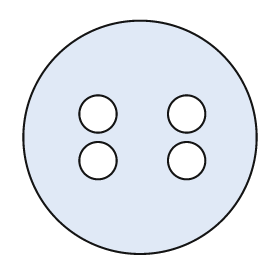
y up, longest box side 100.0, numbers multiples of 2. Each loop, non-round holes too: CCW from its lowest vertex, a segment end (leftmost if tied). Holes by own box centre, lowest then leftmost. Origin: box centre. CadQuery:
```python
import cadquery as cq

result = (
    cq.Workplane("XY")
    .moveTo(0.0, 0.0)
    .circle(50.0)
    .moveTo(-18.0, -10.0)
    .circle(8.0)
    .moveTo(20.0, -10.0)
    .circle(8.0)
    .moveTo(-18.0, 10.0)
    .circle(8.0)
    .moveTo(20.0, 10.0)
    .circle(8.0)
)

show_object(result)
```